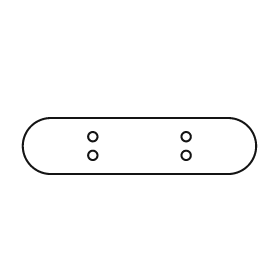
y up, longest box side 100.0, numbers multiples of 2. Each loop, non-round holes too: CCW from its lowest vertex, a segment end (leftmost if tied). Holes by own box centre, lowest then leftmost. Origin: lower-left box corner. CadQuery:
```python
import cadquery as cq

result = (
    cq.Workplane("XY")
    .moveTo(12.0, 0.0)
    .lineTo(88.0, 0.0)
    .threePointArc((100.0, 12.0), (88.0, 24.0))
    .lineTo(12.0, 24.0)
    .threePointArc((0.0, 12.0), (12.0, 0.0))
    .close()
    .moveTo(30.0, 8.0)
    .circle(2.0)
    .moveTo(70.0, 8.0)
    .circle(2.0)
    .moveTo(30.0, 16.0)
    .circle(2.0)
    .moveTo(70.0, 16.0)
    .circle(2.0)
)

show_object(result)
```